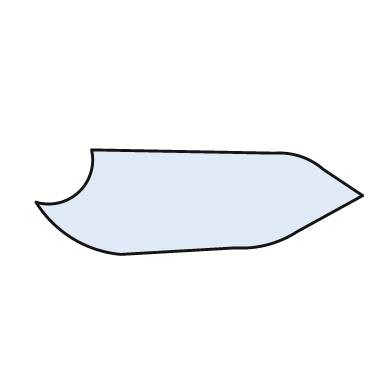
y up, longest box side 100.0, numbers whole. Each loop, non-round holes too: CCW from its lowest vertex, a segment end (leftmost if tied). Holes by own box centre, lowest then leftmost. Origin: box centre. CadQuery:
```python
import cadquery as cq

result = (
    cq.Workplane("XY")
    .moveTo(-24.0, -16.0)
    .lineTo(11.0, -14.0)
    .threePointArc((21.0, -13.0), (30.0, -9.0))
    .lineTo(50.0, 2.0)
    .lineTo(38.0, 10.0)
    .threePointArc((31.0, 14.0), (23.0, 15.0))
    .lineTo(-33.0, 16.0)
    .threePointArc((-37.0, 3.0), (-50.0, 0.0))
    .threePointArc((-39.0, -11.0), (-24.0, -16.0))
    .close()
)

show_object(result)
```